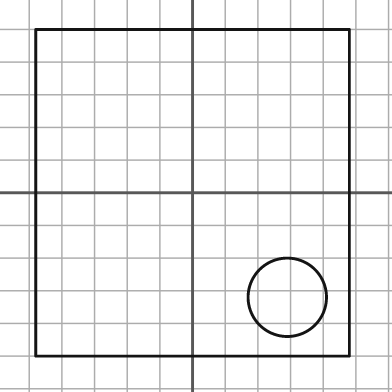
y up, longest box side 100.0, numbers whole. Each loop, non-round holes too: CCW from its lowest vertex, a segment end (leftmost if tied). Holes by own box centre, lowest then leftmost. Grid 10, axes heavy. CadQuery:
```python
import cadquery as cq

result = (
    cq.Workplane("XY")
    .moveTo(-48.0, -50.0)
    .lineTo(48.0, -50.0)
    .lineTo(48.0, 50.0)
    .lineTo(-48.0, 50.0)
    .close()
    .moveTo(29.0, -32.0)
    .circle(12.0)
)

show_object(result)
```